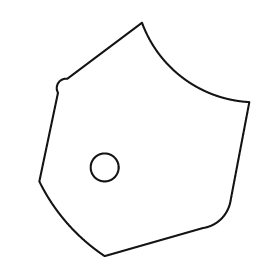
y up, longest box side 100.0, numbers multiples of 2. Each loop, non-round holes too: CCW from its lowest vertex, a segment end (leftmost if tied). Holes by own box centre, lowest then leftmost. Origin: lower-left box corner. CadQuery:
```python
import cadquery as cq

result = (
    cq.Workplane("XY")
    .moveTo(28.0, 0.0)
    .lineTo(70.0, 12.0)
    .threePointArc((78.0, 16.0), (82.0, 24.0))
    .lineTo(90.0, 66.0)
    .threePointArc((62.0, 76.0), (44.0, 100.0))
    .lineTo(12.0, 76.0)
    .threePointArc((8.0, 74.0), (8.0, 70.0))
    .lineTo(0.0, 32.0)
    .threePointArc((12.0, 14.0), (28.0, 0.0))
    .close()
    .moveTo(28.0, 38.0)
    .circle(6.0)
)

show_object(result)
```